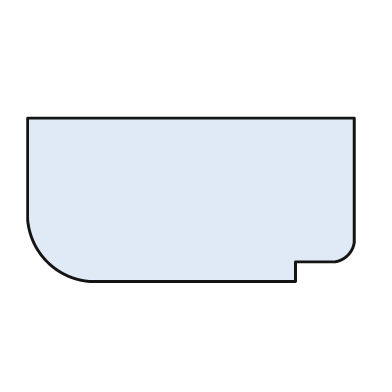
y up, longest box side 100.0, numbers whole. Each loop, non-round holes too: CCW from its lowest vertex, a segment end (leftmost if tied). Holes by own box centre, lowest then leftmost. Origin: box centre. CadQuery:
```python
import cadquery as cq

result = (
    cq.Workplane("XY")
    .moveTo(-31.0, -25.0)
    .lineTo(32.0, -25.0)
    .lineTo(32.0, -19.0)
    .lineTo(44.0, -19.0)
    .threePointArc((48.0, -17.0), (50.0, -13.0))
    .lineTo(50.0, 25.0)
    .lineTo(-50.0, 25.0)
    .lineTo(-50.0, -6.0)
    .threePointArc((-44.0, -19.0), (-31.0, -25.0))
    .close()
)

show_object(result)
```